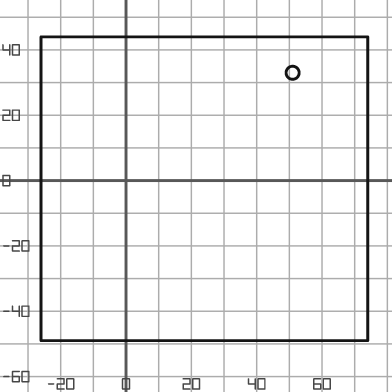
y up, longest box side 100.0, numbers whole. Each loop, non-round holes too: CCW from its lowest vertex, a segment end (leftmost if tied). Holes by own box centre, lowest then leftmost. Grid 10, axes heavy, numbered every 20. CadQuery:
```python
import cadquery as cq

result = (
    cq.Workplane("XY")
    .moveTo(-26.0, -49.0)
    .lineTo(74.0, -49.0)
    .lineTo(74.0, 44.0)
    .lineTo(-26.0, 44.0)
    .close()
    .moveTo(51.0, 33.0)
    .circle(2.0)
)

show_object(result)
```